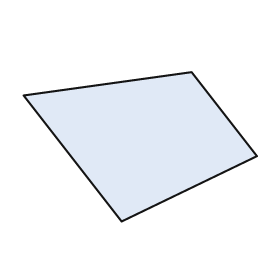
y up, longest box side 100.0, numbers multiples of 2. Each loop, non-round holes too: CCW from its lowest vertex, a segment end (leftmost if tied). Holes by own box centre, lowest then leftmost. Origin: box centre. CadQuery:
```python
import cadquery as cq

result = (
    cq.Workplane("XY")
    .moveTo(-8.0, -32.0)
    .lineTo(50.0, -4.0)
    .lineTo(22.0, 32.0)
    .lineTo(-50.0, 22.0)
    .close()
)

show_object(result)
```